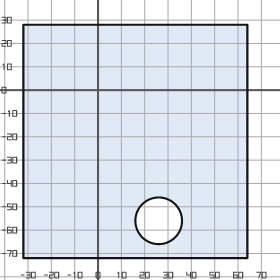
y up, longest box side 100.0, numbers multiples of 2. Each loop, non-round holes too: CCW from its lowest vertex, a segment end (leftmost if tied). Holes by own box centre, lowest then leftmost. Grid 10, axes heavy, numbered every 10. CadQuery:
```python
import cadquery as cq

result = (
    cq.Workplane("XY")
    .moveTo(-32.0, -72.0)
    .lineTo(64.0, -72.0)
    .lineTo(64.0, 28.0)
    .lineTo(-32.0, 28.0)
    .close()
    .moveTo(26.0, -56.0)
    .circle(10.0)
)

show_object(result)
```